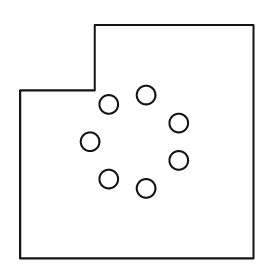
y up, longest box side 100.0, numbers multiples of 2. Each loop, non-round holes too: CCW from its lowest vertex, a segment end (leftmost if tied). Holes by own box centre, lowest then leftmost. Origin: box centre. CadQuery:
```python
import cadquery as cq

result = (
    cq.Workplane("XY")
    .moveTo(-50.0, -50.0)
    .lineTo(50.0, -50.0)
    .lineTo(50.0, 50.0)
    .lineTo(-18.0, 50.0)
    .lineTo(-18.0, 22.0)
    .lineTo(-50.0, 22.0)
    .close()
    .moveTo(4.0, -20.0)
    .circle(4.0)
    .moveTo(-12.0, -16.0)
    .circle(4.0)
    .moveTo(18.0, -8.0)
    .circle(4.0)
    .moveTo(-20.0, 0.0)
    .circle(4.0)
    .moveTo(18.0, 8.0)
    .circle(4.0)
    .moveTo(-12.0, 16.0)
    .circle(4.0)
    .moveTo(4.0, 20.0)
    .circle(4.0)
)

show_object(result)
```